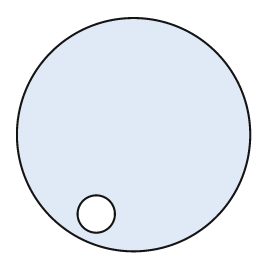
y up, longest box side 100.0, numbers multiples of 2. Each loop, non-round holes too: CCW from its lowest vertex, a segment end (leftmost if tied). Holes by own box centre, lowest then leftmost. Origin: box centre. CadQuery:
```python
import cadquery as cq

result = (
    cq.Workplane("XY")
    .moveTo(0.0, 0.0)
    .circle(50.0)
    .moveTo(-16.0, -34.0)
    .circle(8.0)
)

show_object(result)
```